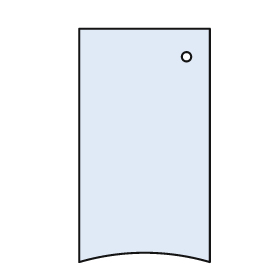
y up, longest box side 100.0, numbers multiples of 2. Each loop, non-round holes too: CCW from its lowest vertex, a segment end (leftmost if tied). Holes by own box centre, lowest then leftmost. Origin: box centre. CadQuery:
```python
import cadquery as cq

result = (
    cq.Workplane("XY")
    .moveTo(-28.0, -50.0)
    .threePointArc((0.0, -46.0), (28.0, -50.0))
    .lineTo(28.0, 50.0)
    .lineTo(-28.0, 50.0)
    .close()
    .moveTo(18.0, 38.0)
    .circle(2.0)
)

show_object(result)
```